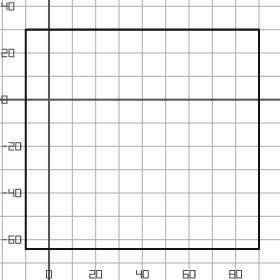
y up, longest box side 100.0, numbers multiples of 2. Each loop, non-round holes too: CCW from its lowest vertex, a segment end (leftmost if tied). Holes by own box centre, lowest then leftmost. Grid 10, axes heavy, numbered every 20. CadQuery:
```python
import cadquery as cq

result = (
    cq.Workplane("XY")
    .moveTo(-10.0, -64.0)
    .lineTo(90.0, -64.0)
    .lineTo(90.0, 30.0)
    .lineTo(-10.0, 30.0)
    .close()
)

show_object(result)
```